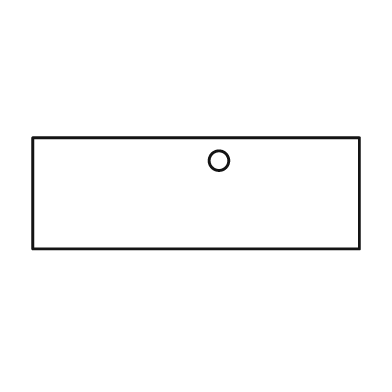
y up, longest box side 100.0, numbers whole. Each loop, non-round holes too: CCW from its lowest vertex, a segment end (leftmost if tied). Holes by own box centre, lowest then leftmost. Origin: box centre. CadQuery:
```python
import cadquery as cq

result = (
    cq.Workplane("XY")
    .moveTo(-50.0, -17.0)
    .lineTo(50.0, -17.0)
    .lineTo(50.0, 17.0)
    .lineTo(-50.0, 17.0)
    .close()
    .moveTo(7.0, 10.0)
    .circle(3.0)
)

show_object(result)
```